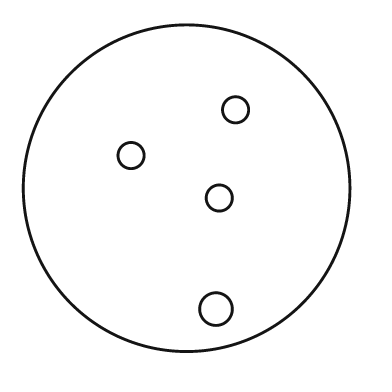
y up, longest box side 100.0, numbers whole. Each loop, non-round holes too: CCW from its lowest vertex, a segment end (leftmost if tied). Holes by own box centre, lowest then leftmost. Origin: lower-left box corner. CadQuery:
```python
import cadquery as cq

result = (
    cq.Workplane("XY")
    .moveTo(50.0, 50.0)
    .circle(50.0)
    .moveTo(59.0, 13.0)
    .circle(5.0)
    .moveTo(60.0, 47.0)
    .circle(4.0)
    .moveTo(33.0, 60.0)
    .circle(4.0)
    .moveTo(65.0, 74.0)
    .circle(4.0)
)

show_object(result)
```